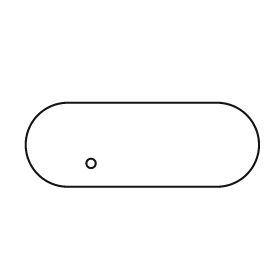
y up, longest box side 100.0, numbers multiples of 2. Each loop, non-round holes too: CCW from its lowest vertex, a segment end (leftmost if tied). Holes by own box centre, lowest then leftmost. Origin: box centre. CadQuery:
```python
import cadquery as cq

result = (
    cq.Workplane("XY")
    .moveTo(-32.0, -18.0)
    .lineTo(32.0, -18.0)
    .threePointArc((50.0, 0.0), (32.0, 18.0))
    .lineTo(-32.0, 18.0)
    .threePointArc((-50.0, 0.0), (-32.0, -18.0))
    .close()
    .moveTo(-22.0, -8.0)
    .circle(2.0)
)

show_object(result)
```